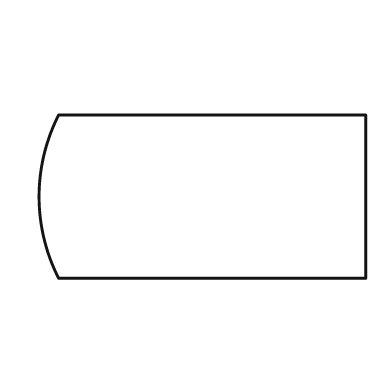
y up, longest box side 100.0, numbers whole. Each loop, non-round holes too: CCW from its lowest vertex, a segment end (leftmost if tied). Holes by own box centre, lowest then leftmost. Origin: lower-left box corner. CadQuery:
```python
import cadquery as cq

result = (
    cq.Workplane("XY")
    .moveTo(6.0, 0.0)
    .lineTo(100.0, 0.0)
    .lineTo(100.0, 50.0)
    .lineTo(6.0, 50.0)
    .threePointArc((0.0, 25.0), (6.0, 0.0))
    .close()
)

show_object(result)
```